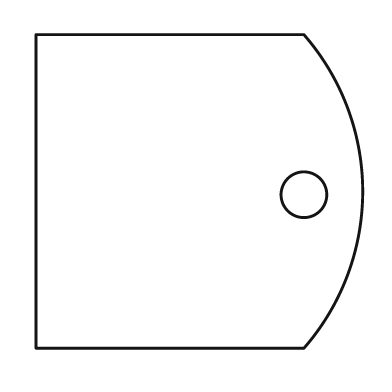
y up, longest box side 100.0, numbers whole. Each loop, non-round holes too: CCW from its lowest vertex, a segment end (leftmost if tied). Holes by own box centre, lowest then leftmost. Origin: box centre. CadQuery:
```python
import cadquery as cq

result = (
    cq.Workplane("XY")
    .moveTo(-50.0, -48.0)
    .lineTo(32.0, -48.0)
    .threePointArc((50.0, 0.0), (32.0, 48.0))
    .lineTo(-50.0, 48.0)
    .close()
    .moveTo(32.0, -1.0)
    .circle(7.0)
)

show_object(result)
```